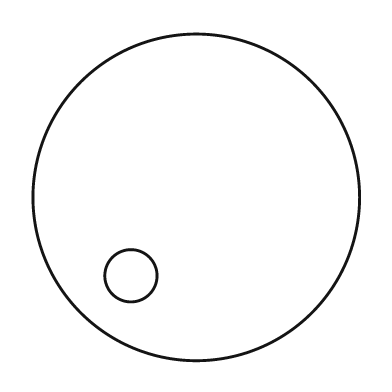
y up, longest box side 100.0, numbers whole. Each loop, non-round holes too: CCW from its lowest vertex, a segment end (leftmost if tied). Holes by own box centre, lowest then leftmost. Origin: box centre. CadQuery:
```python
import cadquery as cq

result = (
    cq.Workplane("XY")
    .moveTo(0.0, 0.0)
    .circle(50.0)
    .moveTo(-20.0, -24.0)
    .circle(8.0)
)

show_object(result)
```